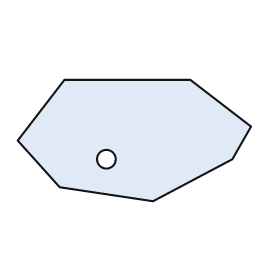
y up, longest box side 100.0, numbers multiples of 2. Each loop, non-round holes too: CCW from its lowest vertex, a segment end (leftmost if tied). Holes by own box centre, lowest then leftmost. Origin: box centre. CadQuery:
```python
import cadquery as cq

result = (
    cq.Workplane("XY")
    .moveTo(8.0, -26.0)
    .lineTo(42.0, -8.0)
    .lineTo(50.0, 6.0)
    .lineTo(24.0, 26.0)
    .lineTo(-30.0, 26.0)
    .lineTo(-50.0, 0.0)
    .lineTo(-32.0, -20.0)
    .close()
    .moveTo(-12.0, -8.0)
    .circle(4.0)
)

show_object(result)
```